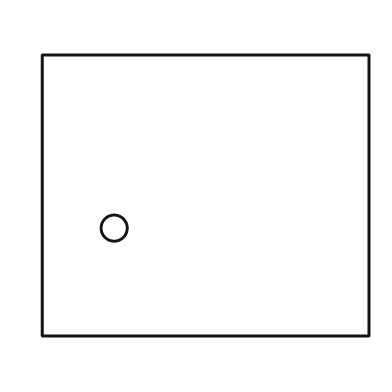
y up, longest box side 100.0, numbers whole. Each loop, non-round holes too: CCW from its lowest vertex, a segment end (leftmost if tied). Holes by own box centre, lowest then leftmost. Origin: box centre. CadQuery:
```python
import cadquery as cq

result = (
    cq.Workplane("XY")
    .moveTo(-50.0, -43.0)
    .lineTo(50.0, -43.0)
    .lineTo(50.0, 43.0)
    .lineTo(-50.0, 43.0)
    .close()
    .moveTo(-28.0, -10.0)
    .circle(4.0)
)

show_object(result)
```